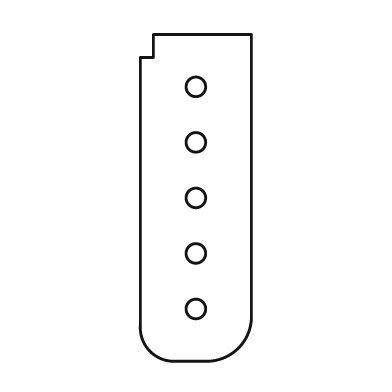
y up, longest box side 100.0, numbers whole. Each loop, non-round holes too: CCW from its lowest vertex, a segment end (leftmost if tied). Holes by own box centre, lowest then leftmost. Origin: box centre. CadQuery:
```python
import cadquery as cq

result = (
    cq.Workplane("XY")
    .moveTo(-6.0, -50.0)
    .lineTo(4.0, -50.0)
    .threePointArc((13.0, -46.0), (17.0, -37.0))
    .lineTo(17.0, 50.0)
    .lineTo(-13.0, 50.0)
    .lineTo(-13.0, 43.0)
    .lineTo(-17.0, 43.0)
    .lineTo(-17.0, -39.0)
    .threePointArc((-14.0, -47.0), (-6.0, -50.0))
    .close()
    .moveTo(0.0, -34.0)
    .circle(3.0)
    .moveTo(0.0, -17.0)
    .circle(3.0)
    .moveTo(0.0, 0.0)
    .circle(3.0)
    .moveTo(0.0, 17.0)
    .circle(3.0)
    .moveTo(0.0, 34.0)
    .circle(3.0)
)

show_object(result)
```